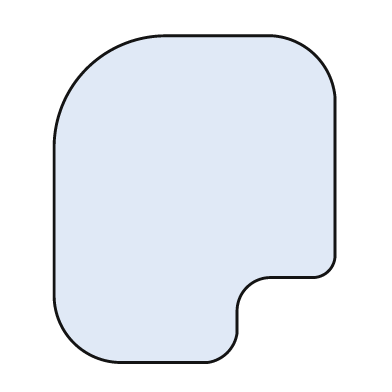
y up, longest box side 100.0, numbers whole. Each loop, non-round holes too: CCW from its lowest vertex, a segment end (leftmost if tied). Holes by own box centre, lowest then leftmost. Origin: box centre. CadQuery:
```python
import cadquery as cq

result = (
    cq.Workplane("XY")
    .moveTo(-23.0, -50.0)
    .lineTo(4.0, -50.0)
    .threePointArc((10.0, -47.0), (13.0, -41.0))
    .lineTo(13.0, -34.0)
    .threePointArc((16.0, -27.0), (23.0, -24.0))
    .lineTo(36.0, -24.0)
    .threePointArc((41.0, -22.0), (43.0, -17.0))
    .lineTo(43.0, 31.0)
    .threePointArc((37.0, 44.0), (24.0, 50.0))
    .lineTo(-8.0, 50.0)
    .threePointArc((-33.0, 40.0), (-43.0, 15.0))
    .lineTo(-43.0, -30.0)
    .threePointArc((-37.0, -44.0), (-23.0, -50.0))
    .close()
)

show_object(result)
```